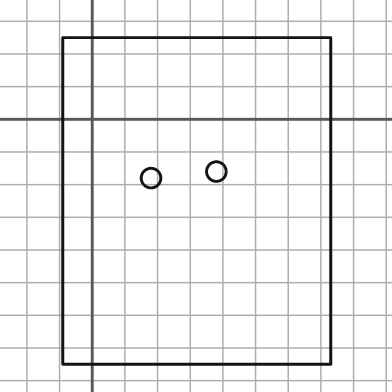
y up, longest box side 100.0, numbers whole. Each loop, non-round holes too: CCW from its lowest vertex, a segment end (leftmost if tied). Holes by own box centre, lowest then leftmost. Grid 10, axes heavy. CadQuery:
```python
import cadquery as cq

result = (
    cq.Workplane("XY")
    .moveTo(-9.0, -75.0)
    .lineTo(73.0, -75.0)
    .lineTo(73.0, 25.0)
    .lineTo(-9.0, 25.0)
    .close()
    .moveTo(18.0, -18.0)
    .circle(3.0)
    .moveTo(38.0, -16.0)
    .circle(3.0)
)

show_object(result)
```